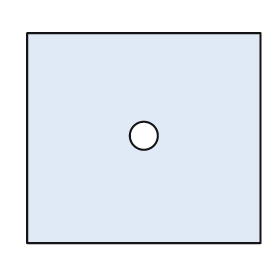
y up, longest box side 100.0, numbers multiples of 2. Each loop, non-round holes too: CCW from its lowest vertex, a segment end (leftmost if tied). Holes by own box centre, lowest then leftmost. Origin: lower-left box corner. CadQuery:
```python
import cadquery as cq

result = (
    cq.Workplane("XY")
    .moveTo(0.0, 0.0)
    .lineTo(100.0, 0.0)
    .lineTo(100.0, 90.0)
    .lineTo(0.0, 90.0)
    .close()
    .moveTo(50.0, 46.0)
    .circle(6.0)
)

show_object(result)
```